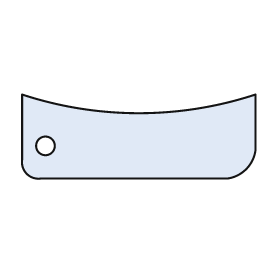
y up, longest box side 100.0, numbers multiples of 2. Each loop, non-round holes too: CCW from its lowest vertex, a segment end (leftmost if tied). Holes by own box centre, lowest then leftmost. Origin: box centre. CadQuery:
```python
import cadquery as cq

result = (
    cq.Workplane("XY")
    .moveTo(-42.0, -18.0)
    .lineTo(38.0, -18.0)
    .threePointArc((46.0, -14.0), (50.0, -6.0))
    .lineTo(50.0, 18.0)
    .threePointArc((0.0, 10.0), (-50.0, 18.0))
    .lineTo(-50.0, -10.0)
    .threePointArc((-48.0, -16.0), (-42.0, -18.0))
    .close()
    .moveTo(-40.0, -4.0)
    .circle(4.0)
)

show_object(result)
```